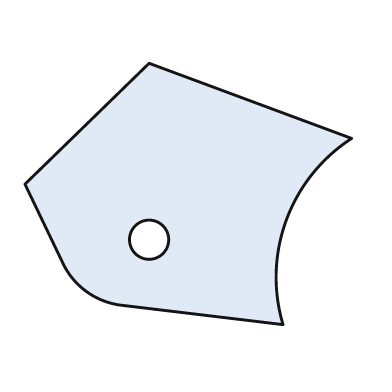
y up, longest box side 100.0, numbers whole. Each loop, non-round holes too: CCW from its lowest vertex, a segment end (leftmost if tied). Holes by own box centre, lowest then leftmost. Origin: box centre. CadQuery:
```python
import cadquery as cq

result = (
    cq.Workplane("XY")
    .moveTo(29.0, -40.0)
    .threePointArc((30.0, -8.0), (50.0, 17.0))
    .lineTo(-12.0, 40.0)
    .lineTo(-50.0, 3.0)
    .lineTo(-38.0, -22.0)
    .threePointArc((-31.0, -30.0), (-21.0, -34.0))
    .close()
    .moveTo(-12.0, -14.0)
    .circle(6.0)
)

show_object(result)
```